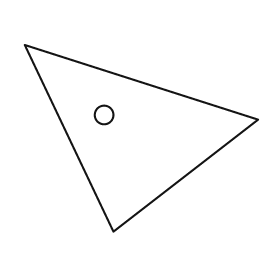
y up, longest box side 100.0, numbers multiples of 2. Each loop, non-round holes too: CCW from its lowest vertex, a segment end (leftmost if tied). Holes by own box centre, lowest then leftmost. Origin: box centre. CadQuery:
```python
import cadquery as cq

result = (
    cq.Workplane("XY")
    .moveTo(-12.0, -40.0)
    .lineTo(50.0, 8.0)
    .lineTo(-50.0, 40.0)
    .close()
    .moveTo(-16.0, 10.0)
    .circle(4.0)
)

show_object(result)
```